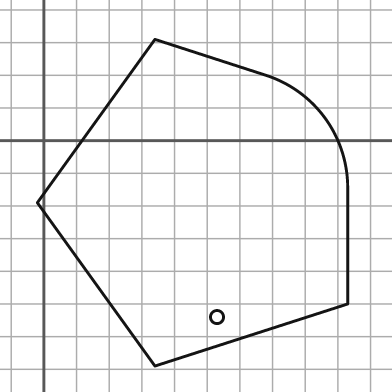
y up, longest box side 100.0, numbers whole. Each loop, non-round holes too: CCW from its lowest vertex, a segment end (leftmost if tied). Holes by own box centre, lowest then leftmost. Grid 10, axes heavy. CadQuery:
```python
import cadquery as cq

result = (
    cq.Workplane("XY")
    .moveTo(34.0, -69.0)
    .lineTo(93.0, -50.0)
    .lineTo(93.0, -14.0)
    .threePointArc((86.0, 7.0), (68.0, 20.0))
    .lineTo(34.0, 31.0)
    .lineTo(-2.0, -19.0)
    .close()
    .moveTo(53.0, -54.0)
    .circle(2.0)
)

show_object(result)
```